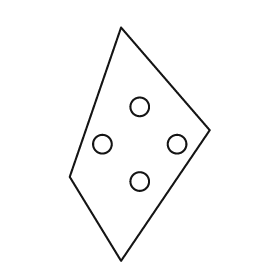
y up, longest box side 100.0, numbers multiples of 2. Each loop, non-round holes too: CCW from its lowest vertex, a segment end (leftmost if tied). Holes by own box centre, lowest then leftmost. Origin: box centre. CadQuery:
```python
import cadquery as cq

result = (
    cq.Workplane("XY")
    .moveTo(-8.0, -50.0)
    .lineTo(30.0, 6.0)
    .lineTo(-8.0, 50.0)
    .lineTo(-30.0, -14.0)
    .close()
    .moveTo(0.0, -16.0)
    .circle(4.0)
    .moveTo(-16.0, 0.0)
    .circle(4.0)
    .moveTo(16.0, 0.0)
    .circle(4.0)
    .moveTo(0.0, 16.0)
    .circle(4.0)
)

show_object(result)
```